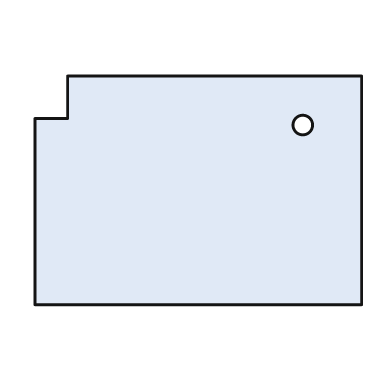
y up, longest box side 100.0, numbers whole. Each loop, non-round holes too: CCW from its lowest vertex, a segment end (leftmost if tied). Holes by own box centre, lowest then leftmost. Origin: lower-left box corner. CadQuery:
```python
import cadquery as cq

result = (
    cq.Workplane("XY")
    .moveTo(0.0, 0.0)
    .lineTo(100.0, 0.0)
    .lineTo(100.0, 70.0)
    .lineTo(10.0, 70.0)
    .lineTo(10.0, 57.0)
    .lineTo(0.0, 57.0)
    .close()
    .moveTo(82.0, 55.0)
    .circle(3.0)
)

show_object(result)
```